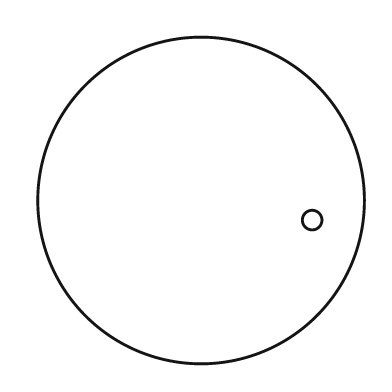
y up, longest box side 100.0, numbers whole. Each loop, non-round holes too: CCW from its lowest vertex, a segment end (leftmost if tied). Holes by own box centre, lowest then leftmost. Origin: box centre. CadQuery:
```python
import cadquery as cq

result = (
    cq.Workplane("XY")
    .moveTo(0.0, 0.0)
    .circle(50.0)
    .moveTo(34.0, -6.0)
    .circle(3.0)
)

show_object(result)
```